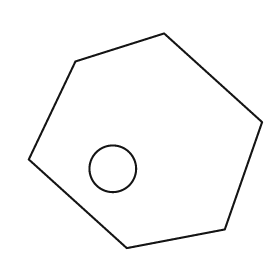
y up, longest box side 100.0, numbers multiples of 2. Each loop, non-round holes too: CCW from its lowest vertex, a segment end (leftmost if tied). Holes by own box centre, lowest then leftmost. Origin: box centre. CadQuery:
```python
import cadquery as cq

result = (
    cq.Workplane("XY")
    .moveTo(-8.0, -46.0)
    .lineTo(34.0, -38.0)
    .lineTo(50.0, 8.0)
    .lineTo(8.0, 46.0)
    .lineTo(-30.0, 34.0)
    .lineTo(-50.0, -8.0)
    .close()
    .moveTo(-14.0, -12.0)
    .circle(10.0)
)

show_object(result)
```